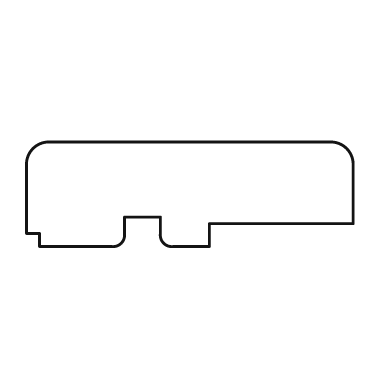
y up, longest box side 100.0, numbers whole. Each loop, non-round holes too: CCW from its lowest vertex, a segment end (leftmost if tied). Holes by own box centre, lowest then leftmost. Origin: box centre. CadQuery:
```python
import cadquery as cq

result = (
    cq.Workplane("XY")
    .moveTo(-46.0, -16.0)
    .lineTo(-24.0, -16.0)
    .threePointArc((-21.0, -15.0), (-20.0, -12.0))
    .lineTo(-20.0, -7.0)
    .lineTo(-9.0, -7.0)
    .lineTo(-9.0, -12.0)
    .threePointArc((-8.0, -15.0), (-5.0, -16.0))
    .lineTo(6.0, -16.0)
    .lineTo(6.0, -9.0)
    .lineTo(50.0, -9.0)
    .lineTo(50.0, 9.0)
    .threePointArc((48.0, 14.0), (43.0, 16.0))
    .lineTo(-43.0, 16.0)
    .threePointArc((-48.0, 14.0), (-50.0, 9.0))
    .lineTo(-50.0, -12.0)
    .lineTo(-46.0, -12.0)
    .close()
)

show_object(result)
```